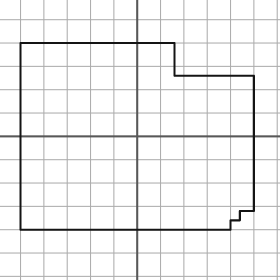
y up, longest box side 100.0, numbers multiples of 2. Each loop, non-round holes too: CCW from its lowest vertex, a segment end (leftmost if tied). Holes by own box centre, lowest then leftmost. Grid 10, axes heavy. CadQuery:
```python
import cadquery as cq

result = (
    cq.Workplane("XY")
    .moveTo(-50.0, -40.0)
    .lineTo(40.0, -40.0)
    .lineTo(40.0, -36.0)
    .lineTo(44.0, -36.0)
    .lineTo(44.0, -32.0)
    .lineTo(50.0, -32.0)
    .lineTo(50.0, 26.0)
    .lineTo(16.0, 26.0)
    .lineTo(16.0, 40.0)
    .lineTo(-50.0, 40.0)
    .close()
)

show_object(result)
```